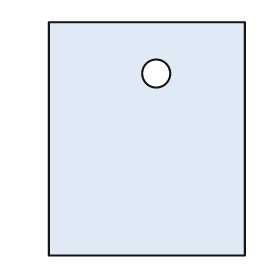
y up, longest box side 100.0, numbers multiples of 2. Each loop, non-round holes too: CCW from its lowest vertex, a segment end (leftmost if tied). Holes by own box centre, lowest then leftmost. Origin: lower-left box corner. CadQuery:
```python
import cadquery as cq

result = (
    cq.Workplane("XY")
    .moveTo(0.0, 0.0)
    .lineTo(84.0, 0.0)
    .lineTo(84.0, 100.0)
    .lineTo(0.0, 100.0)
    .close()
    .moveTo(46.0, 78.0)
    .circle(6.0)
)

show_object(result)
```